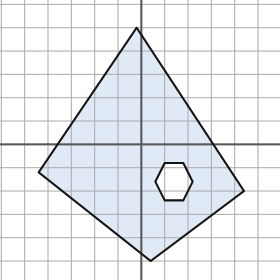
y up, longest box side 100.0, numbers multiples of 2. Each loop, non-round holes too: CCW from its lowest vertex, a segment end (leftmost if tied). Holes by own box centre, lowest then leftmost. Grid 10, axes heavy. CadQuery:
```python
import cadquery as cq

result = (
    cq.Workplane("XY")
    .moveTo(4.0, -50.0)
    .lineTo(44.0, -20.0)
    .lineTo(-2.0, 50.0)
    .lineTo(-44.0, -12.0)
    .close()
    .moveTo(10.0, -24.0)
    .lineTo(18.0, -24.0)
    .lineTo(22.0, -16.0)
    .lineTo(18.0, -8.0)
    .lineTo(10.0, -8.0)
    .lineTo(6.0, -16.0)
    .close()
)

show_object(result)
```